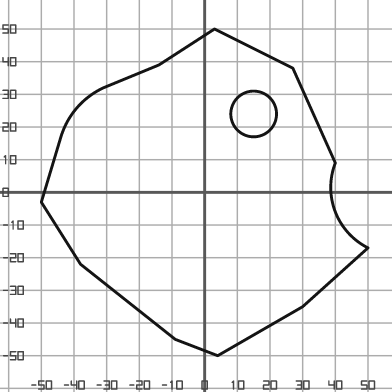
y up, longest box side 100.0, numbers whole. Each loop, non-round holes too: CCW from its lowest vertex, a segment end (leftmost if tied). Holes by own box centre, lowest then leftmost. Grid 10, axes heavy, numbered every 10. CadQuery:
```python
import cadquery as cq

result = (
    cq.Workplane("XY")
    .moveTo(4.0, -50.0)
    .lineTo(30.0, -35.0)
    .lineTo(50.0, -17.0)
    .threePointArc((40.0, -6.0), (40.0, 9.0))
    .lineTo(27.0, 38.0)
    .lineTo(3.0, 50.0)
    .lineTo(-14.0, 39.0)
    .lineTo(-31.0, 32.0)
    .threePointArc((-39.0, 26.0), (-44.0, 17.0))
    .lineTo(-50.0, -3.0)
    .lineTo(-38.0, -22.0)
    .lineTo(-9.0, -45.0)
    .close()
    .moveTo(15.0, 24.0)
    .circle(7.0)
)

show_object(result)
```